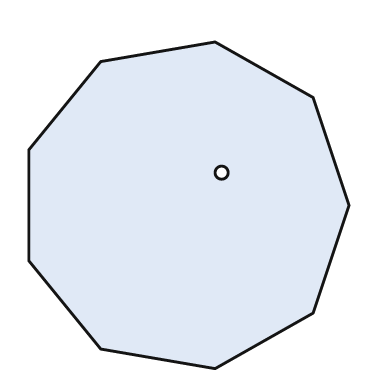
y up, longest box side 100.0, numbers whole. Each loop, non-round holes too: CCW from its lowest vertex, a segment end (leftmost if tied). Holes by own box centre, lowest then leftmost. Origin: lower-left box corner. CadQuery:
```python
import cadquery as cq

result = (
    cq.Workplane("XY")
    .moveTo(57.0, 0.0)
    .lineTo(87.0, 17.0)
    .lineTo(98.0, 50.0)
    .lineTo(87.0, 83.0)
    .lineTo(57.0, 100.0)
    .lineTo(22.0, 94.0)
    .lineTo(0.0, 67.0)
    .lineTo(0.0, 33.0)
    .lineTo(22.0, 6.0)
    .close()
    .moveTo(59.0, 60.0)
    .circle(2.0)
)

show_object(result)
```